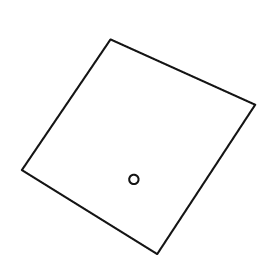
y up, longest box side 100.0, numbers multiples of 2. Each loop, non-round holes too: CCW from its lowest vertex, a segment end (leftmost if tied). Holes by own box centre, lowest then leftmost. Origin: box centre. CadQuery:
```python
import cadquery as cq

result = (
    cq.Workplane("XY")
    .moveTo(8.0, -46.0)
    .lineTo(50.0, 18.0)
    .lineTo(-12.0, 46.0)
    .lineTo(-50.0, -10.0)
    .close()
    .moveTo(-2.0, -14.0)
    .circle(2.0)
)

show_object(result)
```